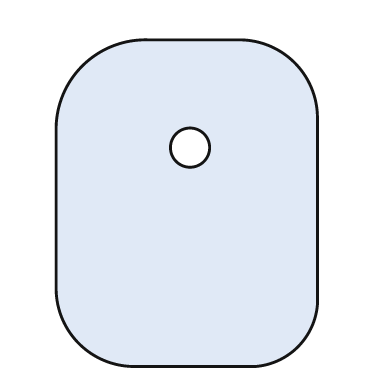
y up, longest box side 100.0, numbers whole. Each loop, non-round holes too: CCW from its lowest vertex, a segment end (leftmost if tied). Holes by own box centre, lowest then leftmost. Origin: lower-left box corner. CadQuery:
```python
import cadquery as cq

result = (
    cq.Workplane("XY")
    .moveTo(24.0, 0.0)
    .lineTo(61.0, 0.0)
    .threePointArc((74.0, 6.0), (80.0, 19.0))
    .lineTo(80.0, 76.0)
    .threePointArc((73.0, 93.0), (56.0, 100.0))
    .lineTo(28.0, 100.0)
    .threePointArc((8.0, 92.0), (0.0, 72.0))
    .lineTo(0.0, 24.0)
    .threePointArc((7.0, 7.0), (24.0, 0.0))
    .close()
    .moveTo(41.0, 67.0)
    .circle(6.0)
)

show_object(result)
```